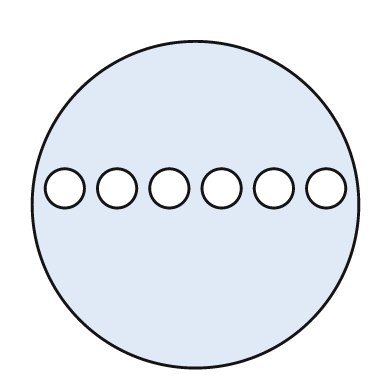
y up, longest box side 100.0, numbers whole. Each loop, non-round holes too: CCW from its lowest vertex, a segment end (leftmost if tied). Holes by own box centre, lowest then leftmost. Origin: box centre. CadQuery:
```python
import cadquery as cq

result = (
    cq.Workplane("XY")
    .moveTo(0.0, 0.0)
    .circle(50.0)
    .moveTo(-40.0, 5.0)
    .circle(6.0)
    .moveTo(-24.0, 5.0)
    .circle(6.0)
    .moveTo(-8.0, 5.0)
    .circle(6.0)
    .moveTo(8.0, 5.0)
    .circle(6.0)
    .moveTo(24.0, 5.0)
    .circle(6.0)
    .moveTo(40.0, 5.0)
    .circle(6.0)
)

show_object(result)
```